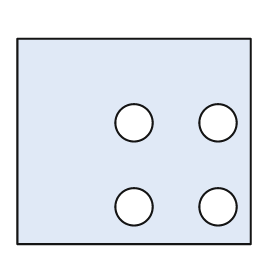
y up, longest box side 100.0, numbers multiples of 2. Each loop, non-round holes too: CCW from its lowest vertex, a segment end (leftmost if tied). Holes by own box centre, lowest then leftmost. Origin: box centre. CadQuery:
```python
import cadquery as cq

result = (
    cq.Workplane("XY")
    .moveTo(-50.0, -44.0)
    .lineTo(50.0, -44.0)
    .lineTo(50.0, 44.0)
    .lineTo(-50.0, 44.0)
    .close()
    .moveTo(0.0, -28.0)
    .circle(8.0)
    .moveTo(36.0, -28.0)
    .circle(8.0)
    .moveTo(0.0, 8.0)
    .circle(8.0)
    .moveTo(36.0, 8.0)
    .circle(8.0)
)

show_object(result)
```